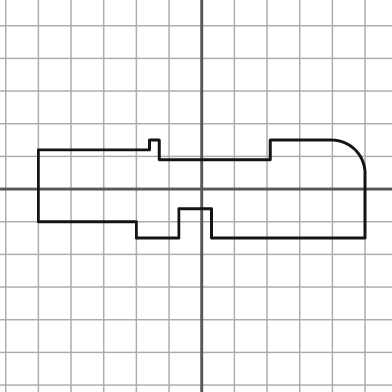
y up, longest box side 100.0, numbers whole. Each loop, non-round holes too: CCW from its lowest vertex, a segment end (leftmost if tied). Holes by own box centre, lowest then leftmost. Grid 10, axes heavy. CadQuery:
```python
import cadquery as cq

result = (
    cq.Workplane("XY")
    .moveTo(-20.0, -15.0)
    .lineTo(-7.0, -15.0)
    .lineTo(-7.0, -6.0)
    .lineTo(3.0, -6.0)
    .lineTo(3.0, -15.0)
    .lineTo(50.0, -15.0)
    .lineTo(50.0, 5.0)
    .threePointArc((47.0, 12.0), (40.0, 15.0))
    .lineTo(21.0, 15.0)
    .lineTo(21.0, 9.0)
    .lineTo(-13.0, 9.0)
    .lineTo(-13.0, 15.0)
    .lineTo(-16.0, 15.0)
    .lineTo(-16.0, 12.0)
    .lineTo(-50.0, 12.0)
    .lineTo(-50.0, -10.0)
    .lineTo(-20.0, -10.0)
    .close()
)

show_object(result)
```